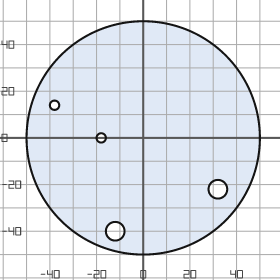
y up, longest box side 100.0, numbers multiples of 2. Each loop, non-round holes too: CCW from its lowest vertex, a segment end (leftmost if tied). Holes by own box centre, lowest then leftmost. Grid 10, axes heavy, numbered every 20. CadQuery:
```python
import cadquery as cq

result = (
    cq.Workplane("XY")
    .moveTo(0.0, 0.0)
    .circle(50.0)
    .moveTo(-12.0, -40.0)
    .circle(4.0)
    .moveTo(32.0, -22.0)
    .circle(4.0)
    .moveTo(-18.0, 0.0)
    .circle(2.0)
    .moveTo(-38.0, 14.0)
    .circle(2.0)
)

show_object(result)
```